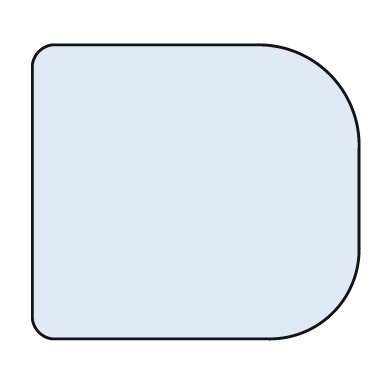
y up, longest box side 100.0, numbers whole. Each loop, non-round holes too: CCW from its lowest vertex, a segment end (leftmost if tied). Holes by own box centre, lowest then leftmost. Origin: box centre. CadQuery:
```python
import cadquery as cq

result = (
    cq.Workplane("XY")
    .moveTo(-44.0, -45.0)
    .lineTo(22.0, -45.0)
    .threePointArc((42.0, -37.0), (50.0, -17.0))
    .lineTo(50.0, 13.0)
    .threePointArc((41.0, 36.0), (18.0, 45.0))
    .lineTo(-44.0, 45.0)
    .threePointArc((-48.0, 43.0), (-50.0, 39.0))
    .lineTo(-50.0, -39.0)
    .threePointArc((-48.0, -43.0), (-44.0, -45.0))
    .close()
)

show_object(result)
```